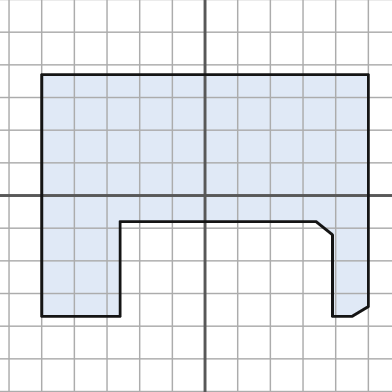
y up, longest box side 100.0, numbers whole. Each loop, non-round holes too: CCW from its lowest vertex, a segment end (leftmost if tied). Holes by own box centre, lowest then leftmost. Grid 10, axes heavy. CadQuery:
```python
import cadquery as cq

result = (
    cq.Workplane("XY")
    .moveTo(-50.0, -37.0)
    .lineTo(-26.0, -37.0)
    .lineTo(-26.0, -8.0)
    .lineTo(34.0, -8.0)
    .lineTo(39.0, -12.0)
    .lineTo(39.0, -37.0)
    .lineTo(45.0, -37.0)
    .lineTo(50.0, -34.0)
    .lineTo(50.0, 37.0)
    .lineTo(-50.0, 37.0)
    .close()
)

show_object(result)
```